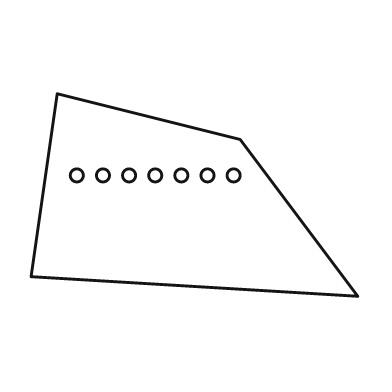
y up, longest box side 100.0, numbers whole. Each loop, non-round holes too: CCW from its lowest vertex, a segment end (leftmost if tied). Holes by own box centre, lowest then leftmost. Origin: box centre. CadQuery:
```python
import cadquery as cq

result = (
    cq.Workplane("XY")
    .moveTo(50.0, -31.0)
    .lineTo(14.0, 17.0)
    .lineTo(-42.0, 31.0)
    .lineTo(-50.0, -25.0)
    .close()
    .moveTo(-36.0, 6.0)
    .circle(2.0)
    .moveTo(-28.0, 6.0)
    .circle(2.0)
    .moveTo(-20.0, 6.0)
    .circle(2.0)
    .moveTo(-12.0, 6.0)
    .circle(2.0)
    .moveTo(-4.0, 6.0)
    .circle(2.0)
    .moveTo(4.0, 6.0)
    .circle(2.0)
    .moveTo(12.0, 6.0)
    .circle(2.0)
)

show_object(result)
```